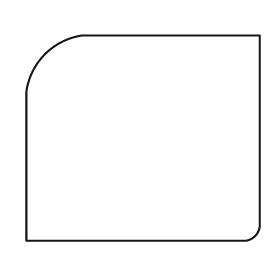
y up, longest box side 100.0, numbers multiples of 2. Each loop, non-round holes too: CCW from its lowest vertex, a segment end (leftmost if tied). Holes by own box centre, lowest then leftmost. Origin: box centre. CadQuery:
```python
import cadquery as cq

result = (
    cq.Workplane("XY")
    .moveTo(-50.0, -44.0)
    .lineTo(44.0, -44.0)
    .threePointArc((48.0, -42.0), (50.0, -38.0))
    .lineTo(50.0, 44.0)
    .lineTo(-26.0, 44.0)
    .threePointArc((-42.0, 36.0), (-50.0, 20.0))
    .close()
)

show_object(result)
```